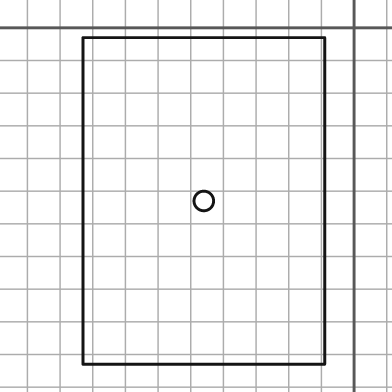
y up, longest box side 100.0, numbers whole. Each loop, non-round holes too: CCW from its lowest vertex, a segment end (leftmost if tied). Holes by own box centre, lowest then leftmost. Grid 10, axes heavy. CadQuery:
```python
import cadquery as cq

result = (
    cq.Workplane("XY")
    .moveTo(-83.0, -103.0)
    .lineTo(-9.0, -103.0)
    .lineTo(-9.0, -3.0)
    .lineTo(-83.0, -3.0)
    .close()
    .moveTo(-46.0, -53.0)
    .circle(3.0)
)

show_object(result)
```